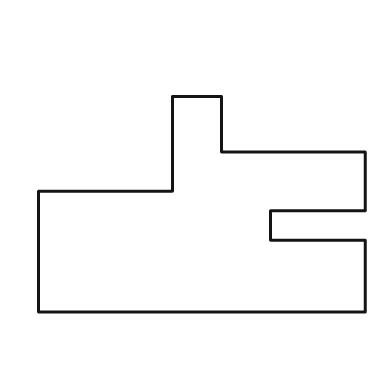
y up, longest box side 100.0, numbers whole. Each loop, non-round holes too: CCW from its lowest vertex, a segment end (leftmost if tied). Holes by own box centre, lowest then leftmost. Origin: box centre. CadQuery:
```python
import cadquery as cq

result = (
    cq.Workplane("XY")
    .moveTo(-50.0, -33.0)
    .lineTo(50.0, -33.0)
    .lineTo(50.0, -11.0)
    .lineTo(21.0, -11.0)
    .lineTo(21.0, -2.0)
    .lineTo(50.0, -2.0)
    .lineTo(50.0, 16.0)
    .lineTo(6.0, 16.0)
    .lineTo(6.0, 33.0)
    .lineTo(-9.0, 33.0)
    .lineTo(-9.0, 4.0)
    .lineTo(-50.0, 4.0)
    .close()
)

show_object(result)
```